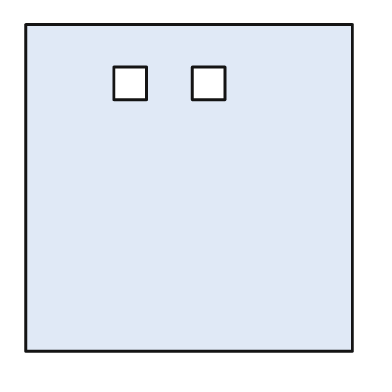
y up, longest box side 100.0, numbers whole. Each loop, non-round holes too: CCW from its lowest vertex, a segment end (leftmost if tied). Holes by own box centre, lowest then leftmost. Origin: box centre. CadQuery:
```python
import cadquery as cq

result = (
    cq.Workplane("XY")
    .moveTo(-50.0, -50.0)
    .lineTo(50.0, -50.0)
    .lineTo(50.0, 50.0)
    .lineTo(-50.0, 50.0)
    .close()
    .moveTo(-23.0, 27.0)
    .lineTo(-13.0, 27.0)
    .lineTo(-13.0, 37.0)
    .lineTo(-23.0, 37.0)
    .close()
    .moveTo(1.0, 27.0)
    .lineTo(11.0, 27.0)
    .lineTo(11.0, 37.0)
    .lineTo(1.0, 37.0)
    .close()
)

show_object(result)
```